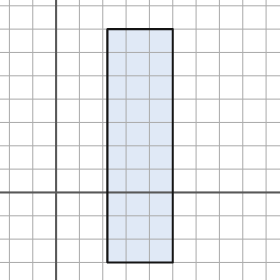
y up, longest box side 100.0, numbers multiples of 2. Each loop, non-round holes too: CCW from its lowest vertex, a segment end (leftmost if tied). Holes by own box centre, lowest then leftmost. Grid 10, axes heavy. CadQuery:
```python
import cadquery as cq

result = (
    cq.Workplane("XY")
    .moveTo(22.0, -30.0)
    .lineTo(50.0, -30.0)
    .lineTo(50.0, 70.0)
    .lineTo(22.0, 70.0)
    .close()
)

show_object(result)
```